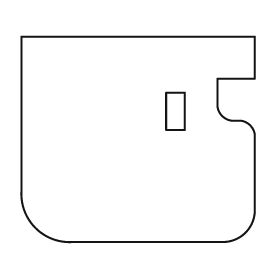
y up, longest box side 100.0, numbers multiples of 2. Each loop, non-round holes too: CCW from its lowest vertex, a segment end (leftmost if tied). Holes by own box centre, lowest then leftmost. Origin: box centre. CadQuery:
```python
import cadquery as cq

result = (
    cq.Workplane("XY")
    .moveTo(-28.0, -44.0)
    .lineTo(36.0, -44.0)
    .threePointArc((46.0, -40.0), (50.0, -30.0))
    .lineTo(50.0, 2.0)
    .threePointArc((48.0, 6.0), (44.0, 8.0))
    .lineTo(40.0, 8.0)
    .threePointArc((36.0, 10.0), (34.0, 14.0))
    .lineTo(34.0, 26.0)
    .lineTo(50.0, 26.0)
    .lineTo(50.0, 44.0)
    .lineTo(-50.0, 44.0)
    .lineTo(-50.0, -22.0)
    .threePointArc((-44.0, -38.0), (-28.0, -44.0))
    .close()
    .moveTo(12.0, 4.0)
    .lineTo(20.0, 4.0)
    .lineTo(20.0, 20.0)
    .lineTo(12.0, 20.0)
    .close()
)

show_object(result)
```